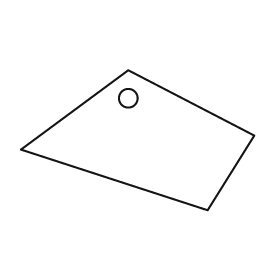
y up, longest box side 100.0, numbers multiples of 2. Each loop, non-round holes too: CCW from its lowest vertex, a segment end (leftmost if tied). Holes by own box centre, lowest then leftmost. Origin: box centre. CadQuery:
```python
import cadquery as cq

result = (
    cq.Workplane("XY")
    .moveTo(30.0, -30.0)
    .lineTo(50.0, 2.0)
    .lineTo(-4.0, 30.0)
    .lineTo(-50.0, -4.0)
    .close()
    .moveTo(-4.0, 18.0)
    .circle(4.0)
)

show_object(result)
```